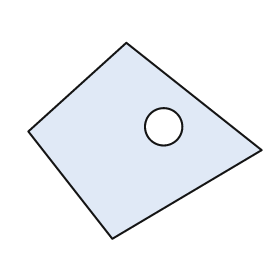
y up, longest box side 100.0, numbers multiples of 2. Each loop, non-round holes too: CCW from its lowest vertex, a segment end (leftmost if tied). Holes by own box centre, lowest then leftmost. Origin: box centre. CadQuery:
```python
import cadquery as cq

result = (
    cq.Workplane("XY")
    .moveTo(-14.0, -42.0)
    .lineTo(50.0, -4.0)
    .lineTo(-8.0, 42.0)
    .lineTo(-50.0, 4.0)
    .close()
    .moveTo(8.0, 6.0)
    .circle(8.0)
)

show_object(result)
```